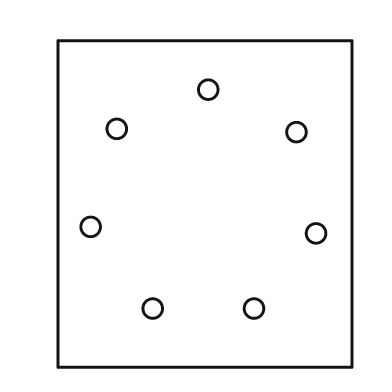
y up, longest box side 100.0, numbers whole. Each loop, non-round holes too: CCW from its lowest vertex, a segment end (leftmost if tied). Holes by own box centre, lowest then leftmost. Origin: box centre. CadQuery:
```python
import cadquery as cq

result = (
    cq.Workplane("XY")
    .moveTo(-45.0, -50.0)
    .lineTo(45.0, -50.0)
    .lineTo(45.0, 50.0)
    .lineTo(-45.0, 50.0)
    .close()
    .moveTo(-16.0, -32.0)
    .circle(3.0)
    .moveTo(15.0, -32.0)
    .circle(3.0)
    .moveTo(34.0, -9.0)
    .circle(3.0)
    .moveTo(-35.0, -7.0)
    .circle(3.0)
    .moveTo(28.0, 22.0)
    .circle(3.0)
    .moveTo(-27.0, 23.0)
    .circle(3.0)
    .moveTo(1.0, 35.0)
    .circle(3.0)
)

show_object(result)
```